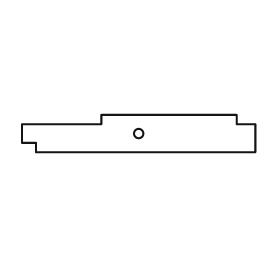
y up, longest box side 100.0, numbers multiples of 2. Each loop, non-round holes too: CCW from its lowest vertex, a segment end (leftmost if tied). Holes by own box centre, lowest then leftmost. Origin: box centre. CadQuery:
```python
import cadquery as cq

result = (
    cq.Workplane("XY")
    .moveTo(-44.0, -8.0)
    .lineTo(50.0, -8.0)
    .lineTo(50.0, 4.0)
    .lineTo(42.0, 4.0)
    .lineTo(42.0, 8.0)
    .lineTo(-16.0, 8.0)
    .lineTo(-16.0, 4.0)
    .lineTo(-50.0, 4.0)
    .lineTo(-50.0, -4.0)
    .lineTo(-44.0, -4.0)
    .close()
    .moveTo(0.0, 0.0)
    .circle(2.0)
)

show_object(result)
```